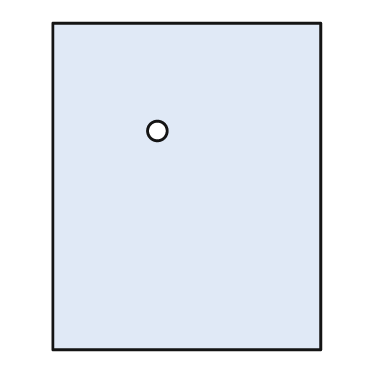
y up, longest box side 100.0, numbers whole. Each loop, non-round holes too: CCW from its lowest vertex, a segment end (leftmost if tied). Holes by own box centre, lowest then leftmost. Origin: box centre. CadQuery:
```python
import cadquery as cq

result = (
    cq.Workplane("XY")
    .moveTo(-41.0, -50.0)
    .lineTo(41.0, -50.0)
    .lineTo(41.0, 50.0)
    .lineTo(-41.0, 50.0)
    .close()
    .moveTo(-9.0, 17.0)
    .circle(3.0)
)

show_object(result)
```